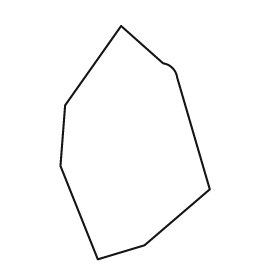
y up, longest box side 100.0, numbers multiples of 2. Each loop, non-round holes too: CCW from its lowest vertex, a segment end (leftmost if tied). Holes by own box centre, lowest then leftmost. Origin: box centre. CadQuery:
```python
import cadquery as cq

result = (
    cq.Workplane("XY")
    .moveTo(-16.0, -50.0)
    .lineTo(4.0, -44.0)
    .lineTo(32.0, -20.0)
    .lineTo(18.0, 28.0)
    .threePointArc((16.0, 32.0), (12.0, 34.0))
    .lineTo(-6.0, 50.0)
    .lineTo(-30.0, 16.0)
    .lineTo(-32.0, -10.0)
    .close()
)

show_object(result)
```